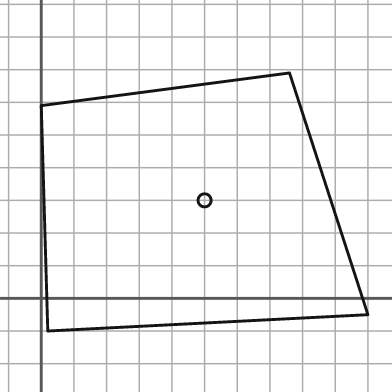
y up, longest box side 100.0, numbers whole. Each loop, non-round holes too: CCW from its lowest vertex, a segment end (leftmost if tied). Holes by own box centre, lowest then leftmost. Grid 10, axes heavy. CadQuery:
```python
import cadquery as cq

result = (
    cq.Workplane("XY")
    .moveTo(2.0, -10.0)
    .lineTo(100.0, -5.0)
    .lineTo(76.0, 69.0)
    .lineTo(0.0, 59.0)
    .close()
    .moveTo(50.0, 30.0)
    .circle(2.0)
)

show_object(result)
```